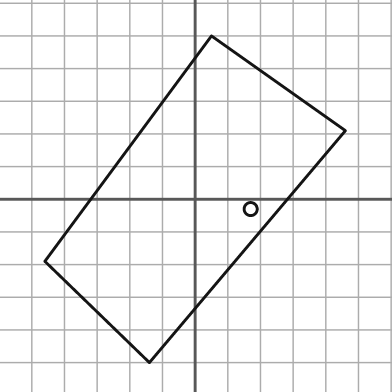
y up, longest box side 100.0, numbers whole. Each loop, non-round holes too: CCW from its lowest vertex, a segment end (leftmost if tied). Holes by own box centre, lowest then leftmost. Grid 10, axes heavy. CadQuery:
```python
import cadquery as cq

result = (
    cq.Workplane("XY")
    .moveTo(-14.0, -50.0)
    .lineTo(46.0, 21.0)
    .lineTo(5.0, 50.0)
    .lineTo(-46.0, -19.0)
    .close()
    .moveTo(17.0, -3.0)
    .circle(2.0)
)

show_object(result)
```